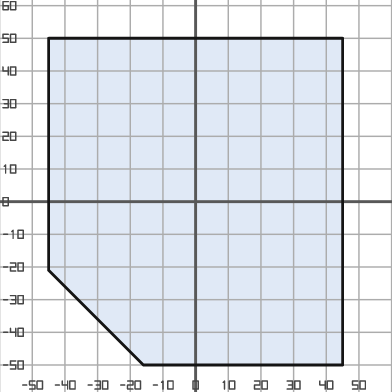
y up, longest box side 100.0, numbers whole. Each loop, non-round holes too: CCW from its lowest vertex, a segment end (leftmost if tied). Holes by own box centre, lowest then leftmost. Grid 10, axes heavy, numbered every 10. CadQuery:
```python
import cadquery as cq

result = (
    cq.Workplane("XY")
    .moveTo(-16.0, -50.0)
    .lineTo(45.0, -50.0)
    .lineTo(45.0, 50.0)
    .lineTo(-45.0, 50.0)
    .lineTo(-45.0, -21.0)
    .close()
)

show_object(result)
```